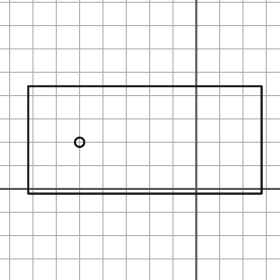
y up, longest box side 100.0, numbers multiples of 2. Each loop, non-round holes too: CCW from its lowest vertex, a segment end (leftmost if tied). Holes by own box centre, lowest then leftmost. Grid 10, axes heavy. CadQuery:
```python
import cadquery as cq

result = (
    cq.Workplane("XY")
    .moveTo(-72.0, -2.0)
    .lineTo(28.0, -2.0)
    .lineTo(28.0, 44.0)
    .lineTo(-72.0, 44.0)
    .close()
    .moveTo(-50.0, 20.0)
    .circle(2.0)
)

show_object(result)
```